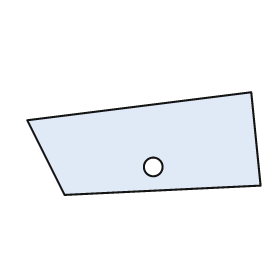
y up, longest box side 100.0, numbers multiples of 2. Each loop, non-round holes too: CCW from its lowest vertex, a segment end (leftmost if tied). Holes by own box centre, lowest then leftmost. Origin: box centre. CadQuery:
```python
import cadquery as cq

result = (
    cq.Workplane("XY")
    .moveTo(-34.0, -22.0)
    .lineTo(50.0, -18.0)
    .lineTo(46.0, 22.0)
    .lineTo(-50.0, 10.0)
    .close()
    .moveTo(4.0, -10.0)
    .circle(4.0)
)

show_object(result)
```